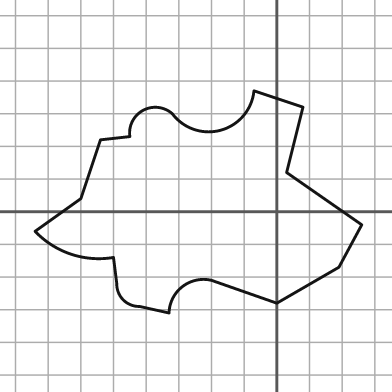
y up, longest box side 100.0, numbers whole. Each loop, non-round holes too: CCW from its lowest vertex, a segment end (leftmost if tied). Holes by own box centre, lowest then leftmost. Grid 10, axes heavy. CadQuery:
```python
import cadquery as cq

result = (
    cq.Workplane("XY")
    .moveTo(-33.0, -31.0)
    .threePointArc((-29.0, -23.0), (-20.0, -21.0))
    .lineTo(0.0, -28.0)
    .lineTo(19.0, -17.0)
    .lineTo(26.0, -4.0)
    .lineTo(3.0, 12.0)
    .lineTo(8.0, 32.0)
    .lineTo(-7.0, 37.0)
    .threePointArc((-17.0, 25.0), (-32.0, 30.0))
    .threePointArc((-41.0, 31.0), (-45.0, 23.0))
    .lineTo(-54.0, 22.0)
    .lineTo(-60.0, 4.0)
    .lineTo(-74.0, -6.0)
    .threePointArc((-63.0, -13.0), (-50.0, -14.0))
    .lineTo(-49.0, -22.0)
    .threePointArc((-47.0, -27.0), (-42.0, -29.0))
    .close()
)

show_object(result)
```